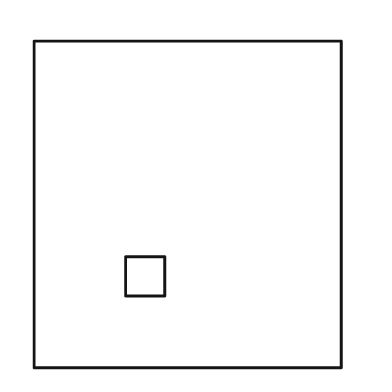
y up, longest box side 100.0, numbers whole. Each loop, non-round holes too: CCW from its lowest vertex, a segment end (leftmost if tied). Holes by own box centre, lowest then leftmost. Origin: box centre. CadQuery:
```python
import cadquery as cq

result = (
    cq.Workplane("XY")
    .moveTo(-47.0, -50.0)
    .lineTo(47.0, -50.0)
    .lineTo(47.0, 50.0)
    .lineTo(-47.0, 50.0)
    .close()
    .moveTo(-19.0, -28.0)
    .lineTo(-7.0, -28.0)
    .lineTo(-7.0, -16.0)
    .lineTo(-19.0, -16.0)
    .close()
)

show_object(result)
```